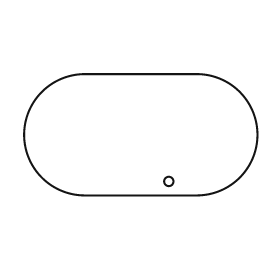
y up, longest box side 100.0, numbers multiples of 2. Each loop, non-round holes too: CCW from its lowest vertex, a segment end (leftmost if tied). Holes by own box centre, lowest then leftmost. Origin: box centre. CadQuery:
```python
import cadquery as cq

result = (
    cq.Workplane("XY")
    .moveTo(-24.0, -26.0)
    .lineTo(24.0, -26.0)
    .threePointArc((50.0, 0.0), (24.0, 26.0))
    .lineTo(-24.0, 26.0)
    .threePointArc((-50.0, 0.0), (-24.0, -26.0))
    .close()
    .moveTo(12.0, -20.0)
    .circle(2.0)
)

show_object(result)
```